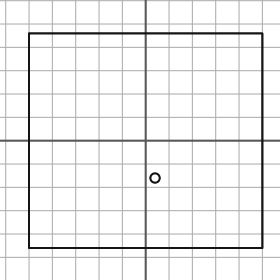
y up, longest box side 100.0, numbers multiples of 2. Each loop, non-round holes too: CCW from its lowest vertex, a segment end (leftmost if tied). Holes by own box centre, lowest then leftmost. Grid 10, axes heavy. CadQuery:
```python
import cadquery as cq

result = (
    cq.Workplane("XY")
    .moveTo(-50.0, -46.0)
    .lineTo(50.0, -46.0)
    .lineTo(50.0, 46.0)
    .lineTo(-50.0, 46.0)
    .close()
    .moveTo(4.0, -16.0)
    .circle(2.0)
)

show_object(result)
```